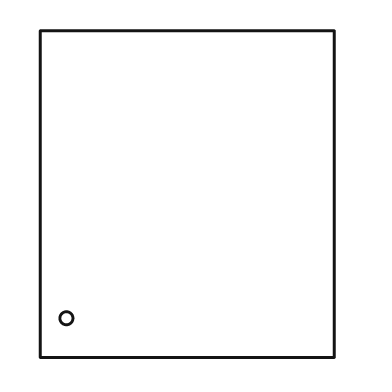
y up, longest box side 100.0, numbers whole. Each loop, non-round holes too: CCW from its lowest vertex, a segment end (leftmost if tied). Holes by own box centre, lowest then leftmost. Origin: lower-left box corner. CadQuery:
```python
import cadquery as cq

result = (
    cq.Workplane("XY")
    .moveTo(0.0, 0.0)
    .lineTo(90.0, 0.0)
    .lineTo(90.0, 100.0)
    .lineTo(0.0, 100.0)
    .close()
    .moveTo(8.0, 12.0)
    .circle(2.0)
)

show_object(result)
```